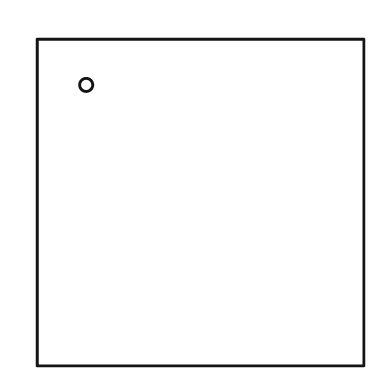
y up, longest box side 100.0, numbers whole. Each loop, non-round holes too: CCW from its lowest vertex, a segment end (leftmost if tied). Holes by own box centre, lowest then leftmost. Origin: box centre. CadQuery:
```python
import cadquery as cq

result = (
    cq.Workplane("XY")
    .moveTo(-50.0, -50.0)
    .lineTo(50.0, -50.0)
    .lineTo(50.0, 50.0)
    .lineTo(-50.0, 50.0)
    .close()
    .moveTo(-35.0, 36.0)
    .circle(2.0)
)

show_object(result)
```